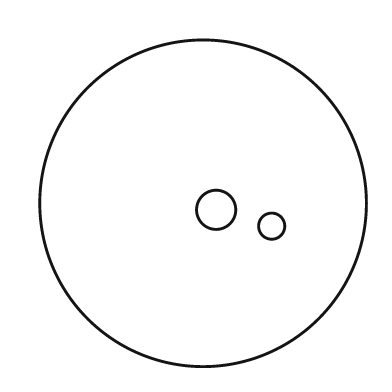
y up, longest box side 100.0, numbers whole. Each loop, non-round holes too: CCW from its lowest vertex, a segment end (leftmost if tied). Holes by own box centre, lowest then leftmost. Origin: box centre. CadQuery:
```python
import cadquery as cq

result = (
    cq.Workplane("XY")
    .moveTo(0.0, 0.0)
    .circle(50.0)
    .moveTo(21.0, -7.0)
    .circle(4.0)
    .moveTo(4.0, -2.0)
    .circle(6.0)
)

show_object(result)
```